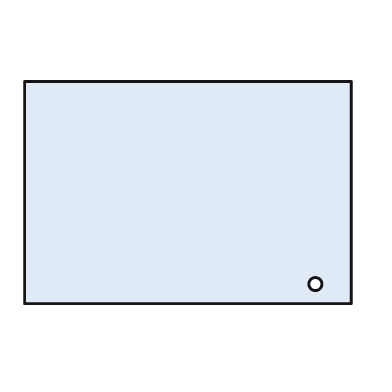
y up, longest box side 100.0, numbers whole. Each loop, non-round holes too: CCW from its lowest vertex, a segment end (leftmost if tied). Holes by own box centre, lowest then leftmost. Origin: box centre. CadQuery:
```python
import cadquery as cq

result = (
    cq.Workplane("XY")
    .moveTo(-50.0, -34.0)
    .lineTo(50.0, -34.0)
    .lineTo(50.0, 34.0)
    .lineTo(-50.0, 34.0)
    .close()
    .moveTo(39.0, -28.0)
    .circle(2.0)
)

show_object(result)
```